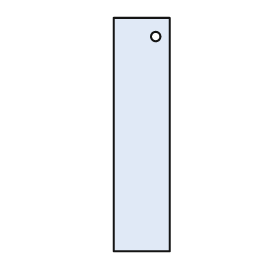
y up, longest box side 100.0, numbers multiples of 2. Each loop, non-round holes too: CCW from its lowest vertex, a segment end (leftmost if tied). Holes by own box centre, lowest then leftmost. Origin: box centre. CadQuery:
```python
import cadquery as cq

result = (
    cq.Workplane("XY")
    .moveTo(-12.0, -50.0)
    .lineTo(12.0, -50.0)
    .lineTo(12.0, 50.0)
    .lineTo(-12.0, 50.0)
    .close()
    .moveTo(6.0, 42.0)
    .circle(2.0)
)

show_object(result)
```